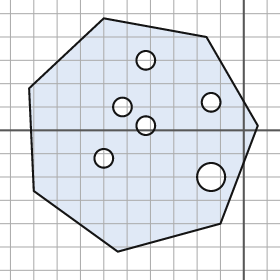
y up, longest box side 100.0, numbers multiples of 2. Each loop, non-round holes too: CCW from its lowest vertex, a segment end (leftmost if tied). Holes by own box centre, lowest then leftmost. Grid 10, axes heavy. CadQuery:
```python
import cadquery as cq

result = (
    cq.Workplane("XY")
    .moveTo(-54.0, -52.0)
    .lineTo(-10.0, -40.0)
    .lineTo(6.0, 2.0)
    .lineTo(-16.0, 40.0)
    .lineTo(-60.0, 48.0)
    .lineTo(-92.0, 18.0)
    .lineTo(-90.0, -26.0)
    .close()
    .moveTo(-14.0, -20.0)
    .circle(6.0)
    .moveTo(-60.0, -12.0)
    .circle(4.0)
    .moveTo(-42.0, 2.0)
    .circle(4.0)
    .moveTo(-52.0, 10.0)
    .circle(4.0)
    .moveTo(-14.0, 12.0)
    .circle(4.0)
    .moveTo(-42.0, 30.0)
    .circle(4.0)
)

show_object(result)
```